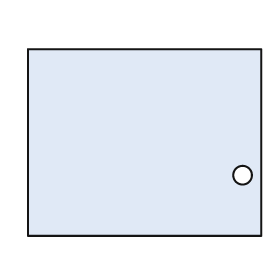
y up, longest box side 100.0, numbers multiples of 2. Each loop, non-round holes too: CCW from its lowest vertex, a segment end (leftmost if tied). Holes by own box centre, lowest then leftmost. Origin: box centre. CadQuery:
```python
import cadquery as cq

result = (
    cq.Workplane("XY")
    .moveTo(-50.0, -40.0)
    .lineTo(50.0, -40.0)
    .lineTo(50.0, 40.0)
    .lineTo(-50.0, 40.0)
    .close()
    .moveTo(42.0, -14.0)
    .circle(4.0)
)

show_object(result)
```